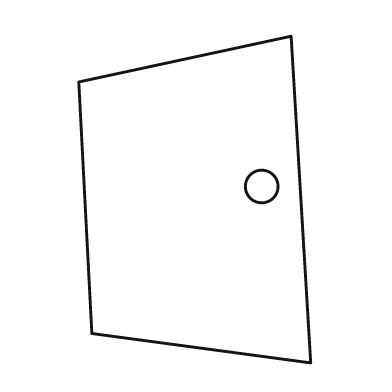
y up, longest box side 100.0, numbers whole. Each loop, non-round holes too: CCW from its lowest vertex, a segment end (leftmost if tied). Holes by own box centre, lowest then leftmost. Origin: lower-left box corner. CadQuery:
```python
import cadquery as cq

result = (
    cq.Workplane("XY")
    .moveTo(71.0, 0.0)
    .lineTo(65.0, 100.0)
    .lineTo(0.0, 86.0)
    .lineTo(4.0, 9.0)
    .close()
    .moveTo(56.0, 54.0)
    .circle(5.0)
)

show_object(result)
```